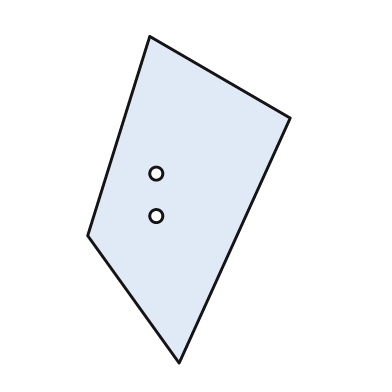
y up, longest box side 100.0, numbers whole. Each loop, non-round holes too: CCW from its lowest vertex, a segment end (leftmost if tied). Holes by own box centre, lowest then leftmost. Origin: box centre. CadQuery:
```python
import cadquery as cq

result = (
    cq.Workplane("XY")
    .moveTo(-3.0, -50.0)
    .lineTo(31.0, 25.0)
    .lineTo(-12.0, 50.0)
    .lineTo(-31.0, -11.0)
    .close()
    .moveTo(-10.0, -5.0)
    .circle(2.0)
    .moveTo(-10.0, 8.0)
    .circle(2.0)
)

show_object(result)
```